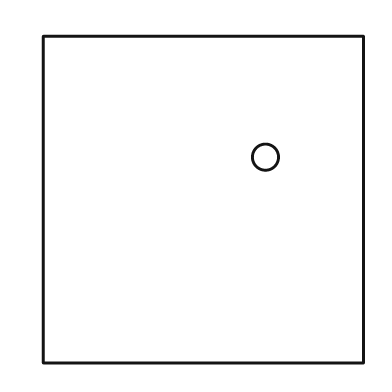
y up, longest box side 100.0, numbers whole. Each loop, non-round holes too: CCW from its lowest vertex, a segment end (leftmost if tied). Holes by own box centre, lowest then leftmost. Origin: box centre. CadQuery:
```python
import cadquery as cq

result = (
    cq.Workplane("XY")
    .moveTo(-49.0, -50.0)
    .lineTo(49.0, -50.0)
    .lineTo(49.0, 50.0)
    .lineTo(-49.0, 50.0)
    .close()
    .moveTo(19.0, 13.0)
    .circle(4.0)
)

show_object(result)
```